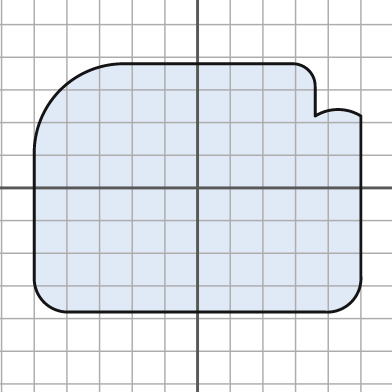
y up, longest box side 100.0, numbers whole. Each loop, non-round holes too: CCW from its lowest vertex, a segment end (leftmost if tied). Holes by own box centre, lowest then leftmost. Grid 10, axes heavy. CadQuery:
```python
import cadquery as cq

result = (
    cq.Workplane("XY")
    .moveTo(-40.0, -38.0)
    .lineTo(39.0, -38.0)
    .threePointArc((47.0, -35.0), (50.0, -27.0))
    .lineTo(50.0, 22.0)
    .threePointArc((43.0, 24.0), (36.0, 22.0))
    .lineTo(36.0, 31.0)
    .threePointArc((34.0, 36.0), (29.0, 38.0))
    .lineTo(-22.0, 38.0)
    .threePointArc((-42.0, 30.0), (-50.0, 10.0))
    .lineTo(-50.0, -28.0)
    .threePointArc((-47.0, -35.0), (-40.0, -38.0))
    .close()
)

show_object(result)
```